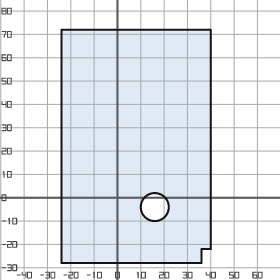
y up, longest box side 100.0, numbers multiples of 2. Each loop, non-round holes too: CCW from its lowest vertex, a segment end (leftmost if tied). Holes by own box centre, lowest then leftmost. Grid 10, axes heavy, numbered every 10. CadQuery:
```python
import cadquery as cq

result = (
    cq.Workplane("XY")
    .moveTo(-24.0, -28.0)
    .lineTo(36.0, -28.0)
    .lineTo(36.0, -22.0)
    .lineTo(40.0, -22.0)
    .lineTo(40.0, 72.0)
    .lineTo(-24.0, 72.0)
    .close()
    .moveTo(16.0, -4.0)
    .circle(6.0)
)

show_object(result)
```